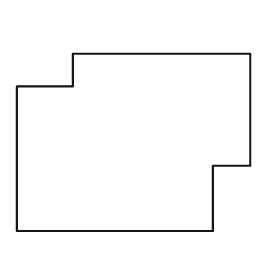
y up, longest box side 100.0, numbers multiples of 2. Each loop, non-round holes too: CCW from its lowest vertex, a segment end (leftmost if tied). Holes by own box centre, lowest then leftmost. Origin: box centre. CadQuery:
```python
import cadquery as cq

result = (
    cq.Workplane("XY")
    .moveTo(-50.0, -38.0)
    .lineTo(34.0, -38.0)
    .lineTo(34.0, -10.0)
    .lineTo(50.0, -10.0)
    .lineTo(50.0, 38.0)
    .lineTo(-26.0, 38.0)
    .lineTo(-26.0, 24.0)
    .lineTo(-50.0, 24.0)
    .close()
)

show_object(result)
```